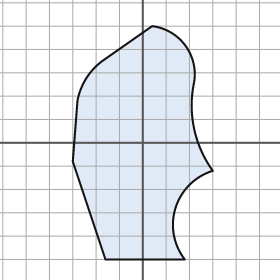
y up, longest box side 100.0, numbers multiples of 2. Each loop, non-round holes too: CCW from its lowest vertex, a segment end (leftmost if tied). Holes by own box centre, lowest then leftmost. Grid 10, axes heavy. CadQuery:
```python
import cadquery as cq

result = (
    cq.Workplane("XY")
    .moveTo(-16.0, -50.0)
    .lineTo(18.0, -50.0)
    .threePointArc((14.0, -28.0), (30.0, -12.0))
    .threePointArc((22.0, 6.0), (22.0, 26.0))
    .threePointArc((18.0, 42.0), (4.0, 50.0))
    .lineTo(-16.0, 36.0)
    .threePointArc((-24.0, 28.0), (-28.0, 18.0))
    .lineTo(-30.0, -8.0)
    .close()
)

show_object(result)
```